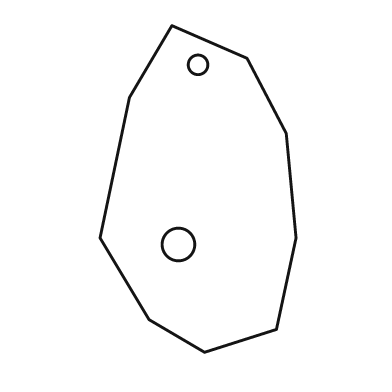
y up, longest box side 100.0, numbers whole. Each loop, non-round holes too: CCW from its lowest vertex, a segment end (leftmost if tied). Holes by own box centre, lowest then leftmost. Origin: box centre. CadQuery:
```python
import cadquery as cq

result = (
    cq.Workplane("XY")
    .moveTo(2.0, -50.0)
    .lineTo(24.0, -43.0)
    .lineTo(30.0, -15.0)
    .lineTo(27.0, 17.0)
    .lineTo(15.0, 40.0)
    .lineTo(-8.0, 50.0)
    .lineTo(-21.0, 28.0)
    .lineTo(-30.0, -15.0)
    .lineTo(-15.0, -40.0)
    .close()
    .moveTo(-6.0, -17.0)
    .circle(5.0)
    .moveTo(0.0, 38.0)
    .circle(3.0)
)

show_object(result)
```